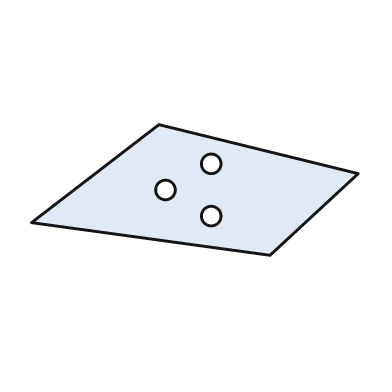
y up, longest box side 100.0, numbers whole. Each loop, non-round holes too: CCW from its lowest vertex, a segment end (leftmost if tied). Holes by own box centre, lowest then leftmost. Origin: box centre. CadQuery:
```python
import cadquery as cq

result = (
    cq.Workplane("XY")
    .moveTo(23.0, -20.0)
    .lineTo(50.0, 5.0)
    .lineTo(-11.0, 20.0)
    .lineTo(-50.0, -10.0)
    .close()
    .moveTo(5.0, -8.0)
    .circle(3.0)
    .moveTo(-9.0, 0.0)
    .circle(3.0)
    .moveTo(5.0, 8.0)
    .circle(3.0)
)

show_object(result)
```